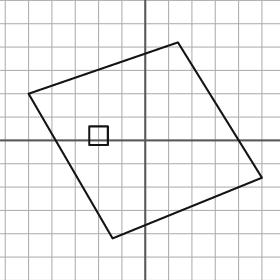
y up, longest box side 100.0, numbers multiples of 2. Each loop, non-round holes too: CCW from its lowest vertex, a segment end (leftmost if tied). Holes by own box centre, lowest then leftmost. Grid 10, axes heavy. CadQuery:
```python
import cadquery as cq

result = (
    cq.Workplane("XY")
    .moveTo(-14.0, -42.0)
    .lineTo(50.0, -16.0)
    .lineTo(14.0, 42.0)
    .lineTo(-50.0, 20.0)
    .close()
    .moveTo(-24.0, -2.0)
    .lineTo(-16.0, -2.0)
    .lineTo(-16.0, 6.0)
    .lineTo(-24.0, 6.0)
    .close()
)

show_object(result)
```